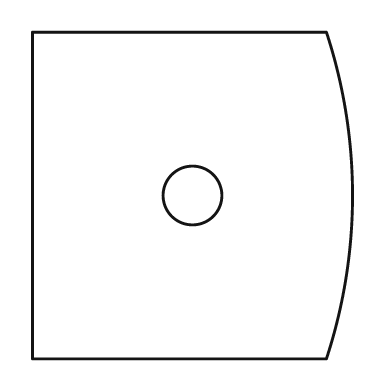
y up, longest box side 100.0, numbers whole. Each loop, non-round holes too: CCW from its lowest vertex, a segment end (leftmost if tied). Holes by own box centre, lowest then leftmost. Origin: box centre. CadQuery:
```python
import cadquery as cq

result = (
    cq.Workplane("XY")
    .moveTo(-49.0, -50.0)
    .lineTo(41.0, -50.0)
    .threePointArc((49.0, 0.0), (41.0, 50.0))
    .lineTo(-49.0, 50.0)
    .close()
    .moveTo(0.0, 0.0)
    .circle(9.0)
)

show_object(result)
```